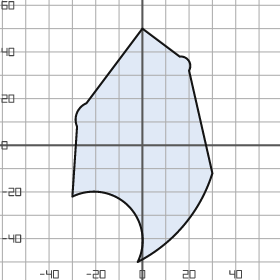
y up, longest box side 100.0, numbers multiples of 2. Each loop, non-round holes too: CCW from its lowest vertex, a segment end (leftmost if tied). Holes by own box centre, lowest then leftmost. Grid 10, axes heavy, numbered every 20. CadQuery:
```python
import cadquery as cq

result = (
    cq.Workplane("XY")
    .moveTo(-2.0, -50.0)
    .threePointArc((18.0, -34.0), (30.0, -12.0))
    .lineTo(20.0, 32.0)
    .threePointArc((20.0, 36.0), (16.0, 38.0))
    .lineTo(0.0, 50.0)
    .lineTo(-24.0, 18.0)
    .threePointArc((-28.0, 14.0), (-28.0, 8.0))
    .lineTo(-30.0, -22.0)
    .threePointArc((-6.0, -26.0), (-2.0, -50.0))
    .close()
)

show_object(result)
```